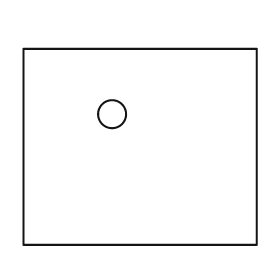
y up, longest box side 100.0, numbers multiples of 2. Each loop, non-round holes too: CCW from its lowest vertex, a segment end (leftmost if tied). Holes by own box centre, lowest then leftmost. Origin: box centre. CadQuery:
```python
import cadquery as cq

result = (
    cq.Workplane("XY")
    .moveTo(-50.0, -42.0)
    .lineTo(50.0, -42.0)
    .lineTo(50.0, 42.0)
    .lineTo(-50.0, 42.0)
    .close()
    .moveTo(-12.0, 14.0)
    .circle(6.0)
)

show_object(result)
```